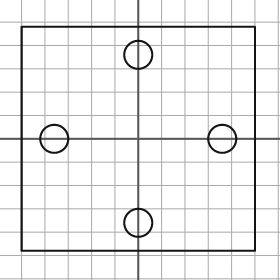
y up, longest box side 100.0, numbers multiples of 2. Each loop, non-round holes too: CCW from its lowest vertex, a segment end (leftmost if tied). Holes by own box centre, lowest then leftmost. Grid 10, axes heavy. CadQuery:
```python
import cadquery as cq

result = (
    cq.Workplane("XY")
    .moveTo(-50.0, -48.0)
    .lineTo(50.0, -48.0)
    .lineTo(50.0, 48.0)
    .lineTo(-50.0, 48.0)
    .close()
    .moveTo(0.0, -36.0)
    .circle(6.0)
    .moveTo(-36.0, 0.0)
    .circle(6.0)
    .moveTo(36.0, 0.0)
    .circle(6.0)
    .moveTo(0.0, 36.0)
    .circle(6.0)
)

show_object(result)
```